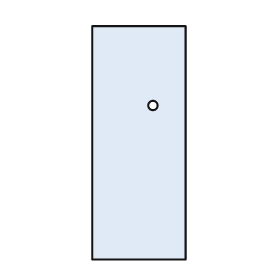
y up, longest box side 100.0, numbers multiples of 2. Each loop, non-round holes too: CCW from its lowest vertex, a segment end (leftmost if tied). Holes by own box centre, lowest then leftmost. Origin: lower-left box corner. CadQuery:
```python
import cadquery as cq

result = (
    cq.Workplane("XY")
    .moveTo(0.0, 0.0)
    .lineTo(40.0, 0.0)
    .lineTo(40.0, 100.0)
    .lineTo(0.0, 100.0)
    .close()
    .moveTo(26.0, 66.0)
    .circle(2.0)
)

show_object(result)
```